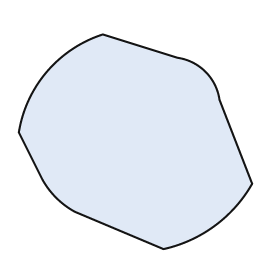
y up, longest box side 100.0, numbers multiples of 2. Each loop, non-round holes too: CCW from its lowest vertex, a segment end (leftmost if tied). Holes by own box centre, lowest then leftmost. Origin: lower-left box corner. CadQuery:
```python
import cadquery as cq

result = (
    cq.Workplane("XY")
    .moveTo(62.0, 0.0)
    .threePointArc((84.0, 10.0), (100.0, 28.0))
    .lineTo(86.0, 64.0)
    .threePointArc((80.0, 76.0), (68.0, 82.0))
    .lineTo(36.0, 92.0)
    .threePointArc((12.0, 76.0), (0.0, 50.0))
    .lineTo(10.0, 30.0)
    .threePointArc((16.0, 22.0), (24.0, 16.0))
    .close()
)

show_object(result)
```